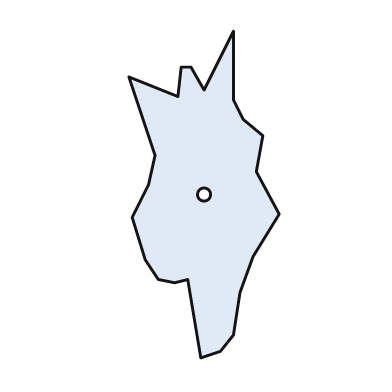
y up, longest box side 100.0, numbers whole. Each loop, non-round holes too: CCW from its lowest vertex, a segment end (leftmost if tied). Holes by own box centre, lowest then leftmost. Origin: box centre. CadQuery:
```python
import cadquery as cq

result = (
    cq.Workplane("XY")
    .moveTo(-1.0, -50.0)
    .lineTo(5.0, -48.0)
    .lineTo(9.0, -43.0)
    .lineTo(11.0, -30.0)
    .lineTo(15.0, -19.0)
    .lineTo(23.0, -6.0)
    .lineTo(16.0, 7.0)
    .lineTo(18.0, 18.0)
    .lineTo(12.0, 23.0)
    .lineTo(9.0, 29.0)
    .lineTo(9.0, 50.0)
    .lineTo(0.0, 32.0)
    .lineTo(-4.0, 39.0)
    .lineTo(-7.0, 39.0)
    .lineTo(-8.0, 30.0)
    .lineTo(-23.0, 36.0)
    .lineTo(-15.0, 12.0)
    .lineTo(-17.0, 3.0)
    .lineTo(-22.0, -7.0)
    .lineTo(-18.0, -20.0)
    .lineTo(-14.0, -26.0)
    .lineTo(-9.0, -27.0)
    .lineTo(-5.0, -26.0)
    .close()
    .moveTo(0.0, 0.0)
    .circle(2.0)
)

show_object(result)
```